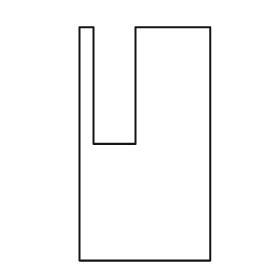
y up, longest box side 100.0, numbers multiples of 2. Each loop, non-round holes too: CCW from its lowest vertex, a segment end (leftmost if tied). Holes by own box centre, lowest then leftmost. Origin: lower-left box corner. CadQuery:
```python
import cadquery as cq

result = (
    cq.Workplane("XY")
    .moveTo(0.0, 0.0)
    .lineTo(56.0, 0.0)
    .lineTo(56.0, 100.0)
    .lineTo(24.0, 100.0)
    .lineTo(24.0, 50.0)
    .lineTo(6.0, 50.0)
    .lineTo(6.0, 100.0)
    .lineTo(0.0, 100.0)
    .close()
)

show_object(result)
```